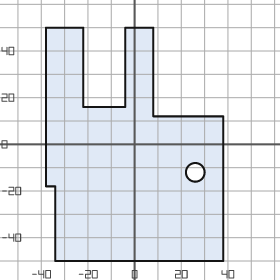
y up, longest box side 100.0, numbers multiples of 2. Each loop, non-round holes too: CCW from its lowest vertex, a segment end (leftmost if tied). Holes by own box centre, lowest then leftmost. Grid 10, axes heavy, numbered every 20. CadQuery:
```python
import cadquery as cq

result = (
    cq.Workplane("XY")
    .moveTo(-34.0, -50.0)
    .lineTo(38.0, -50.0)
    .lineTo(38.0, 12.0)
    .lineTo(8.0, 12.0)
    .lineTo(8.0, 50.0)
    .lineTo(-4.0, 50.0)
    .lineTo(-4.0, 16.0)
    .lineTo(-22.0, 16.0)
    .lineTo(-22.0, 50.0)
    .lineTo(-38.0, 50.0)
    .lineTo(-38.0, -18.0)
    .lineTo(-34.0, -18.0)
    .close()
    .moveTo(26.0, -12.0)
    .circle(4.0)
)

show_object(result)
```